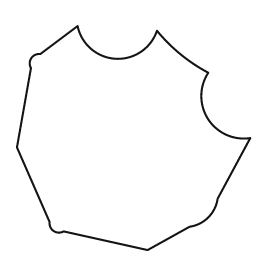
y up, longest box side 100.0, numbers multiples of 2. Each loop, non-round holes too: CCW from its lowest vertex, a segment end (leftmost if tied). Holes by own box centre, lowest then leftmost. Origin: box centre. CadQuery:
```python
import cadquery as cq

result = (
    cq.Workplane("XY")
    .moveTo(6.0, -48.0)
    .lineTo(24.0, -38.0)
    .threePointArc((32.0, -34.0), (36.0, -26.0))
    .lineTo(50.0, 0.0)
    .threePointArc((32.0, 8.0), (32.0, 28.0))
    .threePointArc((20.0, 36.0), (10.0, 46.0))
    .threePointArc((-8.0, 34.0), (-24.0, 48.0))
    .lineTo(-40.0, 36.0)
    .threePointArc((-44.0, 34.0), (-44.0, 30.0))
    .lineTo(-50.0, -4.0)
    .lineTo(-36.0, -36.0)
    .threePointArc((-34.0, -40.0), (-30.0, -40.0))
    .close()
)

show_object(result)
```